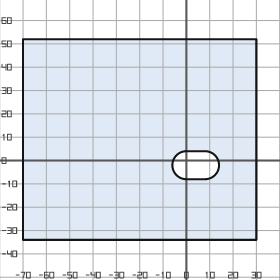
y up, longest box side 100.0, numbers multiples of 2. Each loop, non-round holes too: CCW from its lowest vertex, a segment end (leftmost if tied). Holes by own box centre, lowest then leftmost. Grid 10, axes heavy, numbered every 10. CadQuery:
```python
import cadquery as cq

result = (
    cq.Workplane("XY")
    .moveTo(-70.0, -34.0)
    .lineTo(30.0, -34.0)
    .lineTo(30.0, 52.0)
    .lineTo(-70.0, 52.0)
    .close()
    .moveTo(0.0, -8.0)
    .lineTo(8.0, -8.0)
    .threePointArc((14.0, -2.0), (8.0, 4.0))
    .lineTo(0.0, 4.0)
    .threePointArc((-6.0, -2.0), (0.0, -8.0))
    .close()
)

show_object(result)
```